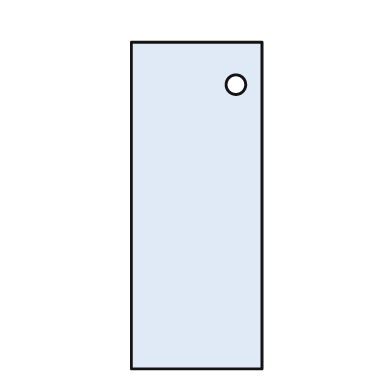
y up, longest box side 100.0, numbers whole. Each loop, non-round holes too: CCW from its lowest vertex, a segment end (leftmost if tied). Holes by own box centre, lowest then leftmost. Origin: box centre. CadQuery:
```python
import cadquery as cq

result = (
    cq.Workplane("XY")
    .moveTo(-20.0, -50.0)
    .lineTo(20.0, -50.0)
    .lineTo(20.0, 50.0)
    .lineTo(-20.0, 50.0)
    .close()
    .moveTo(12.0, 37.0)
    .circle(3.0)
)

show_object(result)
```